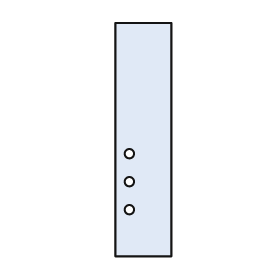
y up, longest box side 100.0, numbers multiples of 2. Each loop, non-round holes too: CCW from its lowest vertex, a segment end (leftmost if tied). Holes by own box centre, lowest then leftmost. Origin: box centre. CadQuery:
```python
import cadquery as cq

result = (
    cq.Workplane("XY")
    .moveTo(-12.0, -50.0)
    .lineTo(12.0, -50.0)
    .lineTo(12.0, 50.0)
    .lineTo(-12.0, 50.0)
    .close()
    .moveTo(-6.0, -30.0)
    .circle(2.0)
    .moveTo(-6.0, -18.0)
    .circle(2.0)
    .moveTo(-6.0, -6.0)
    .circle(2.0)
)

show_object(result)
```